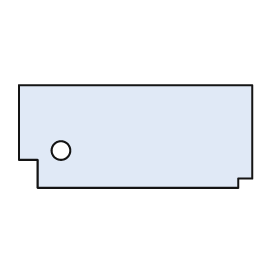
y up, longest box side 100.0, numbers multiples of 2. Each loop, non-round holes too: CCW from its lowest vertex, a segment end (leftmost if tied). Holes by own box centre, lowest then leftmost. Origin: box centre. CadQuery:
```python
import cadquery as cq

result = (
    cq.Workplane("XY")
    .moveTo(-42.0, -22.0)
    .lineTo(44.0, -22.0)
    .lineTo(44.0, -18.0)
    .lineTo(50.0, -18.0)
    .lineTo(50.0, 22.0)
    .lineTo(-50.0, 22.0)
    .lineTo(-50.0, -10.0)
    .lineTo(-42.0, -10.0)
    .close()
    .moveTo(-32.0, -6.0)
    .circle(4.0)
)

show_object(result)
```